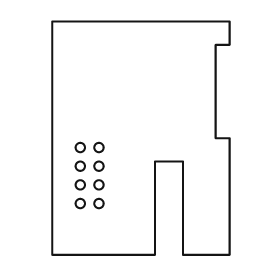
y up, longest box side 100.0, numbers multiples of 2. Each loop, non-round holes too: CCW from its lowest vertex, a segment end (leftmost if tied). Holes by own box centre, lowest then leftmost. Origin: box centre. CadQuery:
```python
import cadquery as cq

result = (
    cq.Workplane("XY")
    .moveTo(-38.0, -50.0)
    .lineTo(6.0, -50.0)
    .lineTo(6.0, -10.0)
    .lineTo(18.0, -10.0)
    .lineTo(18.0, -50.0)
    .lineTo(38.0, -50.0)
    .lineTo(38.0, 0.0)
    .lineTo(32.0, 0.0)
    .lineTo(32.0, 40.0)
    .lineTo(38.0, 40.0)
    .lineTo(38.0, 50.0)
    .lineTo(-38.0, 50.0)
    .close()
    .moveTo(-26.0, -28.0)
    .circle(2.0)
    .moveTo(-18.0, -28.0)
    .circle(2.0)
    .moveTo(-26.0, -20.0)
    .circle(2.0)
    .moveTo(-18.0, -20.0)
    .circle(2.0)
    .moveTo(-26.0, -12.0)
    .circle(2.0)
    .moveTo(-18.0, -12.0)
    .circle(2.0)
    .moveTo(-26.0, -4.0)
    .circle(2.0)
    .moveTo(-18.0, -4.0)
    .circle(2.0)
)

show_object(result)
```